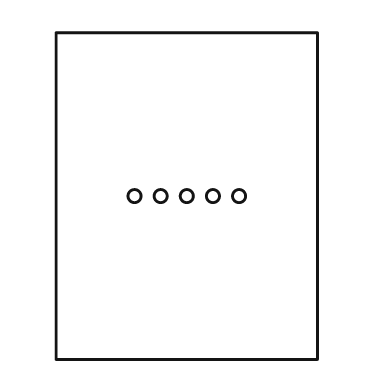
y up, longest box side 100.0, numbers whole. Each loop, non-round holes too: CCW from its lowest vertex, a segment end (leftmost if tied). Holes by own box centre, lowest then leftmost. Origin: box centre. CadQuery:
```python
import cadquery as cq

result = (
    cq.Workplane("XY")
    .moveTo(-40.0, -50.0)
    .lineTo(40.0, -50.0)
    .lineTo(40.0, 50.0)
    .lineTo(-40.0, 50.0)
    .close()
    .moveTo(-16.0, 0.0)
    .circle(2.0)
    .moveTo(-8.0, 0.0)
    .circle(2.0)
    .moveTo(0.0, 0.0)
    .circle(2.0)
    .moveTo(8.0, 0.0)
    .circle(2.0)
    .moveTo(16.0, 0.0)
    .circle(2.0)
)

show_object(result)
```